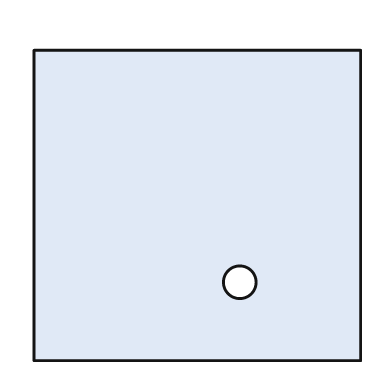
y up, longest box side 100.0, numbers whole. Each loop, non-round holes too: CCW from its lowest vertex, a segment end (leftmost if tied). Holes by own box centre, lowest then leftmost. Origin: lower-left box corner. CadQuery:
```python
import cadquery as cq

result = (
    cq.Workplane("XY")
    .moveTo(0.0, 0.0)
    .lineTo(100.0, 0.0)
    .lineTo(100.0, 95.0)
    .lineTo(0.0, 95.0)
    .close()
    .moveTo(63.0, 24.0)
    .circle(5.0)
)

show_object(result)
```